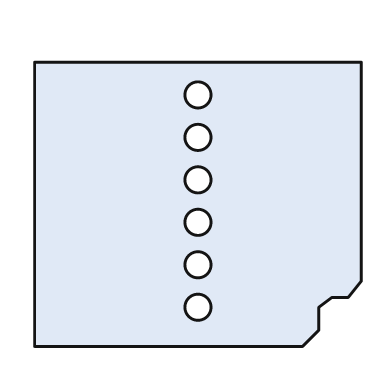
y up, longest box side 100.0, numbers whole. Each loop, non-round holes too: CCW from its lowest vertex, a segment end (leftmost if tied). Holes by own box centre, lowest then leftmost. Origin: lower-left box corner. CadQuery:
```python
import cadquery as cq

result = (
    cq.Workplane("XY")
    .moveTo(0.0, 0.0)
    .lineTo(82.0, 0.0)
    .lineTo(87.0, 5.0)
    .lineTo(87.0, 12.0)
    .lineTo(91.0, 15.0)
    .lineTo(96.0, 15.0)
    .lineTo(100.0, 20.0)
    .lineTo(100.0, 87.0)
    .lineTo(0.0, 87.0)
    .close()
    .moveTo(50.0, 12.0)
    .circle(4.0)
    .moveTo(50.0, 25.0)
    .circle(4.0)
    .moveTo(50.0, 38.0)
    .circle(4.0)
    .moveTo(50.0, 51.0)
    .circle(4.0)
    .moveTo(50.0, 64.0)
    .circle(4.0)
    .moveTo(50.0, 77.0)
    .circle(4.0)
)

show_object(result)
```